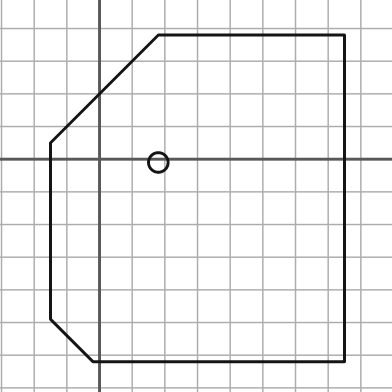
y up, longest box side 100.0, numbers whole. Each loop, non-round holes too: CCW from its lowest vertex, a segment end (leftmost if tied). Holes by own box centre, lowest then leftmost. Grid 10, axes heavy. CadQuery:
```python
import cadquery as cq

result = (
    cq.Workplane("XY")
    .moveTo(-2.0, -62.0)
    .lineTo(75.0, -62.0)
    .lineTo(75.0, 38.0)
    .lineTo(18.0, 38.0)
    .lineTo(-15.0, 5.0)
    .lineTo(-15.0, -49.0)
    .close()
    .moveTo(18.0, -1.0)
    .circle(3.0)
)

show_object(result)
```